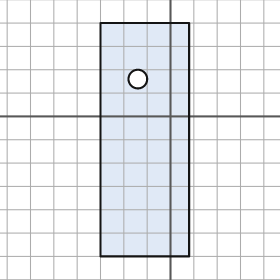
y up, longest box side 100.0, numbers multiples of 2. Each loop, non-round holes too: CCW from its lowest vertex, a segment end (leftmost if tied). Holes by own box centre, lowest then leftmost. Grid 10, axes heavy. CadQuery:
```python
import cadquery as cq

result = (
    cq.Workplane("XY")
    .moveTo(-30.0, -60.0)
    .lineTo(8.0, -60.0)
    .lineTo(8.0, 40.0)
    .lineTo(-30.0, 40.0)
    .close()
    .moveTo(-14.0, 16.0)
    .circle(4.0)
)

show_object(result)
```